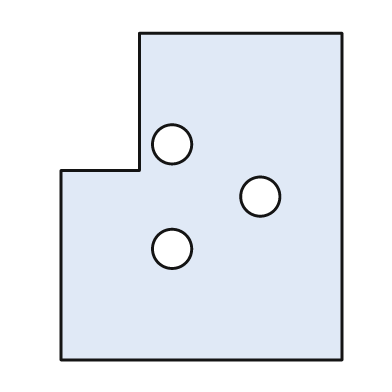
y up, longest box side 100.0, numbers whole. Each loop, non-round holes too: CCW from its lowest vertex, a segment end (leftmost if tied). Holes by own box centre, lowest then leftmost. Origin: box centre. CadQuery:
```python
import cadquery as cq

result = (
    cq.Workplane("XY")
    .moveTo(-43.0, -50.0)
    .lineTo(43.0, -50.0)
    .lineTo(43.0, 50.0)
    .lineTo(-19.0, 50.0)
    .lineTo(-19.0, 8.0)
    .lineTo(-43.0, 8.0)
    .close()
    .moveTo(-9.0, -16.0)
    .circle(6.0)
    .moveTo(18.0, 0.0)
    .circle(6.0)
    .moveTo(-9.0, 16.0)
    .circle(6.0)
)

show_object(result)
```